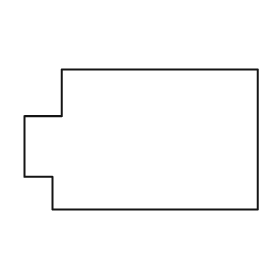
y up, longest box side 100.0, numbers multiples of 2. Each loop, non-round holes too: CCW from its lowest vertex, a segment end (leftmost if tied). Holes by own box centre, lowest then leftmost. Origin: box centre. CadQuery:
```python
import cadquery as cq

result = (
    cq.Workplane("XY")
    .moveTo(-38.0, -30.0)
    .lineTo(50.0, -30.0)
    .lineTo(50.0, 30.0)
    .lineTo(-34.0, 30.0)
    .lineTo(-34.0, 10.0)
    .lineTo(-50.0, 10.0)
    .lineTo(-50.0, -16.0)
    .lineTo(-38.0, -16.0)
    .close()
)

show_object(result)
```